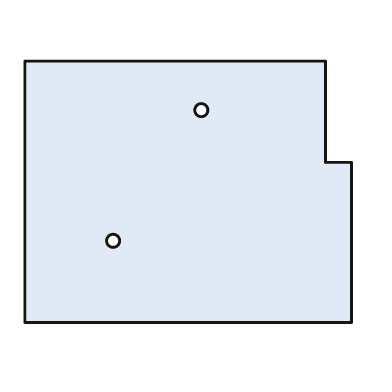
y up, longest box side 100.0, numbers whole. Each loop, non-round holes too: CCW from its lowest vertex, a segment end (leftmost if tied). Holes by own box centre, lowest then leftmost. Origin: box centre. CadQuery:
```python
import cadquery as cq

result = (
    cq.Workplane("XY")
    .moveTo(-50.0, -40.0)
    .lineTo(50.0, -40.0)
    .lineTo(50.0, 9.0)
    .lineTo(42.0, 9.0)
    .lineTo(42.0, 40.0)
    .lineTo(-50.0, 40.0)
    .close()
    .moveTo(-23.0, -15.0)
    .circle(2.0)
    .moveTo(4.0, 25.0)
    .circle(2.0)
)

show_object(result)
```